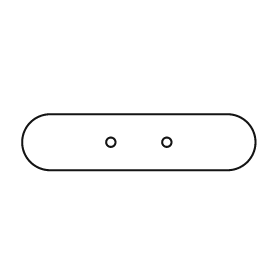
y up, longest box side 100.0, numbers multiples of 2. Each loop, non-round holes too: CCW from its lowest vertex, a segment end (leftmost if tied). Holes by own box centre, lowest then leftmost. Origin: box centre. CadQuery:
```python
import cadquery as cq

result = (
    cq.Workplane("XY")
    .moveTo(-38.0, -12.0)
    .lineTo(38.0, -12.0)
    .threePointArc((50.0, 0.0), (38.0, 12.0))
    .lineTo(-38.0, 12.0)
    .threePointArc((-50.0, 0.0), (-38.0, -12.0))
    .close()
    .moveTo(-12.0, 0.0)
    .circle(2.0)
    .moveTo(12.0, 0.0)
    .circle(2.0)
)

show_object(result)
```